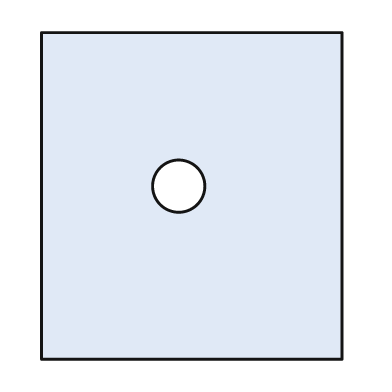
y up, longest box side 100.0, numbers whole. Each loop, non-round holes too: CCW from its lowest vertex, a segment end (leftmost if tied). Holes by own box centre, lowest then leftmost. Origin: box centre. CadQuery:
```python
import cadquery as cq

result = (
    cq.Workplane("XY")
    .moveTo(-46.0, -50.0)
    .lineTo(46.0, -50.0)
    .lineTo(46.0, 50.0)
    .lineTo(-46.0, 50.0)
    .close()
    .moveTo(-4.0, 3.0)
    .circle(8.0)
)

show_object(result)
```